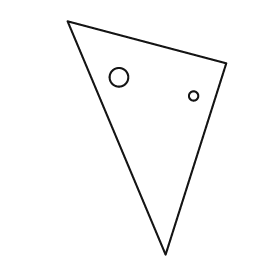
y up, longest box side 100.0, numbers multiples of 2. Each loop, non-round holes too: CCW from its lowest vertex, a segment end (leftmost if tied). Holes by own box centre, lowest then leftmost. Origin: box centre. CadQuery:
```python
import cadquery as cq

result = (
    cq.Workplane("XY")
    .moveTo(8.0, -50.0)
    .lineTo(34.0, 32.0)
    .lineTo(-34.0, 50.0)
    .close()
    .moveTo(20.0, 18.0)
    .circle(2.0)
    .moveTo(-12.0, 26.0)
    .circle(4.0)
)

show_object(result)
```